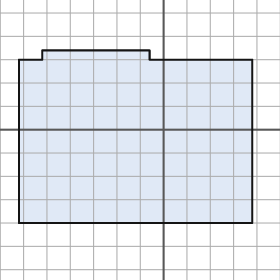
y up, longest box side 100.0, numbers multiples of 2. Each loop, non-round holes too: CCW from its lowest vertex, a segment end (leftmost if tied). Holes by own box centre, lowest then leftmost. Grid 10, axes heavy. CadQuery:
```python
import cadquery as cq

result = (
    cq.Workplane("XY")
    .moveTo(-62.0, -40.0)
    .lineTo(38.0, -40.0)
    .lineTo(38.0, 30.0)
    .lineTo(-6.0, 30.0)
    .lineTo(-6.0, 34.0)
    .lineTo(-52.0, 34.0)
    .lineTo(-52.0, 30.0)
    .lineTo(-62.0, 30.0)
    .close()
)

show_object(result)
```